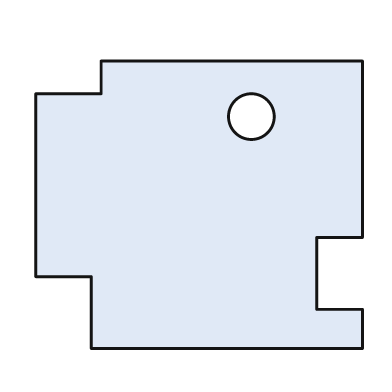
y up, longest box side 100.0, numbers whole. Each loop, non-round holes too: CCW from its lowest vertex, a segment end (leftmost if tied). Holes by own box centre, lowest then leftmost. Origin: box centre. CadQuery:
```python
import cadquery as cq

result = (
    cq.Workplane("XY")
    .moveTo(-33.0, -44.0)
    .lineTo(50.0, -44.0)
    .lineTo(50.0, -32.0)
    .lineTo(36.0, -32.0)
    .lineTo(36.0, -10.0)
    .lineTo(50.0, -10.0)
    .lineTo(50.0, 44.0)
    .lineTo(-30.0, 44.0)
    .lineTo(-30.0, 34.0)
    .lineTo(-50.0, 34.0)
    .lineTo(-50.0, -22.0)
    .lineTo(-33.0, -22.0)
    .close()
    .moveTo(16.0, 27.0)
    .circle(7.0)
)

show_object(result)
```